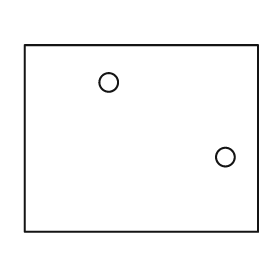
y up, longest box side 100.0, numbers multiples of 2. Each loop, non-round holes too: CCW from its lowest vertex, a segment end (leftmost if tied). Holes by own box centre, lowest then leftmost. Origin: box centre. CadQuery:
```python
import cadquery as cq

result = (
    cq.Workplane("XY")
    .moveTo(-50.0, -40.0)
    .lineTo(50.0, -40.0)
    .lineTo(50.0, 40.0)
    .lineTo(-50.0, 40.0)
    .close()
    .moveTo(36.0, -8.0)
    .circle(4.0)
    .moveTo(-14.0, 24.0)
    .circle(4.0)
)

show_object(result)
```